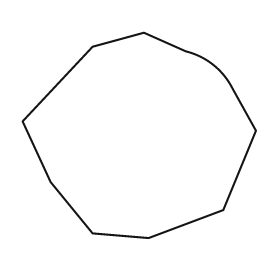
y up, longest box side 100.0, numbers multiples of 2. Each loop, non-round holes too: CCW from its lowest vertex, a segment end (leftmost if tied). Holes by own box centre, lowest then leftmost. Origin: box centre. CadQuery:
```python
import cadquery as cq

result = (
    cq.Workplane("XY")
    .moveTo(4.0, -44.0)
    .lineTo(36.0, -32.0)
    .lineTo(50.0, 2.0)
    .lineTo(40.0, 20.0)
    .threePointArc((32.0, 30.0), (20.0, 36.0))
    .lineTo(2.0, 44.0)
    .lineTo(-20.0, 38.0)
    .lineTo(-50.0, 6.0)
    .lineTo(-38.0, -20.0)
    .lineTo(-20.0, -42.0)
    .close()
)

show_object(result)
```